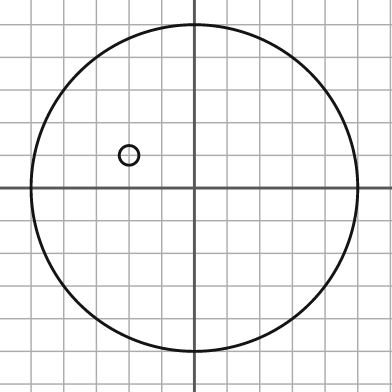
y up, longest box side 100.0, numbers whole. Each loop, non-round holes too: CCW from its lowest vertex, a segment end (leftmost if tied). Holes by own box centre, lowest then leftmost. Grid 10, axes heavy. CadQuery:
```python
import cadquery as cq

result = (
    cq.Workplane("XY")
    .moveTo(0.0, 0.0)
    .circle(50.0)
    .moveTo(-20.0, 10.0)
    .circle(3.0)
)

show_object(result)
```